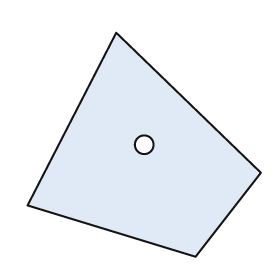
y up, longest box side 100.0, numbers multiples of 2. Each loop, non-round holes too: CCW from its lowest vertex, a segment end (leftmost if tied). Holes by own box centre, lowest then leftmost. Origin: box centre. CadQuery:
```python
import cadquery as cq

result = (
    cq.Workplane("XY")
    .moveTo(22.0, -48.0)
    .lineTo(50.0, -12.0)
    .lineTo(-12.0, 48.0)
    .lineTo(-50.0, -26.0)
    .close()
    .moveTo(0.0, 0.0)
    .circle(4.0)
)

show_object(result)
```